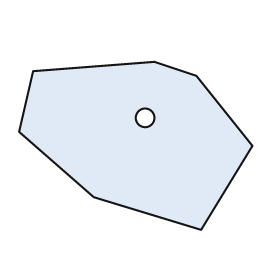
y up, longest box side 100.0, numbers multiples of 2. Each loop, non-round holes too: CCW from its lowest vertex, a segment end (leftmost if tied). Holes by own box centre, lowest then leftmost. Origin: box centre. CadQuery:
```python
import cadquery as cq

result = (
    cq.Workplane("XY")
    .moveTo(28.0, -36.0)
    .lineTo(50.0, 0.0)
    .lineTo(26.0, 30.0)
    .lineTo(8.0, 36.0)
    .lineTo(-44.0, 32.0)
    .lineTo(-50.0, 6.0)
    .lineTo(-18.0, -22.0)
    .close()
    .moveTo(4.0, 12.0)
    .circle(4.0)
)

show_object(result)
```